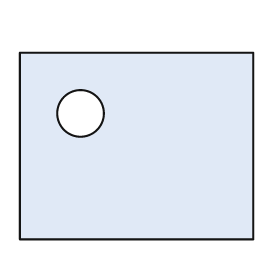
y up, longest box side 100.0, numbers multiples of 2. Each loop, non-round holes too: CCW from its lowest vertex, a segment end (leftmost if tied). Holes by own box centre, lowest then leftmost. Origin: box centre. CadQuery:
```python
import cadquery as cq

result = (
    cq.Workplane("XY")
    .moveTo(-50.0, -40.0)
    .lineTo(50.0, -40.0)
    .lineTo(50.0, 40.0)
    .lineTo(-50.0, 40.0)
    .close()
    .moveTo(-24.0, 14.0)
    .circle(10.0)
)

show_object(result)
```